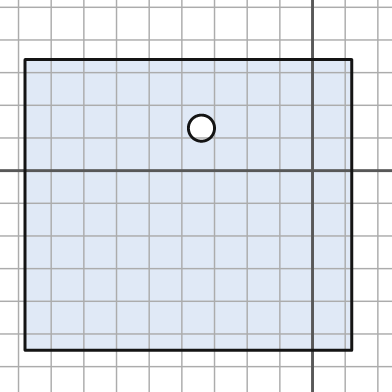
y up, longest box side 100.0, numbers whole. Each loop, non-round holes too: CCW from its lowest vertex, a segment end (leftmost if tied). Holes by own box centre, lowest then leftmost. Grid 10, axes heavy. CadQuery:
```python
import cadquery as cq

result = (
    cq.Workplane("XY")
    .moveTo(-88.0, -55.0)
    .lineTo(12.0, -55.0)
    .lineTo(12.0, 34.0)
    .lineTo(-88.0, 34.0)
    .close()
    .moveTo(-34.0, 13.0)
    .circle(4.0)
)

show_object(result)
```